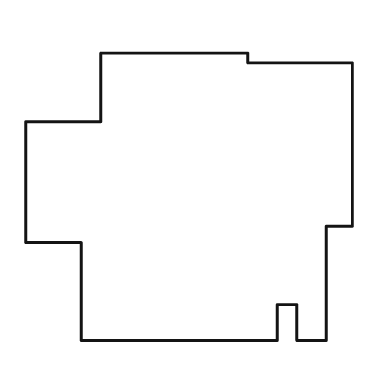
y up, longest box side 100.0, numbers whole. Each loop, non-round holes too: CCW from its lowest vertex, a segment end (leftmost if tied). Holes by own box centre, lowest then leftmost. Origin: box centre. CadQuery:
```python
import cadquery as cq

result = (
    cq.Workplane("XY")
    .moveTo(-33.0, -44.0)
    .lineTo(27.0, -44.0)
    .lineTo(27.0, -33.0)
    .lineTo(33.0, -33.0)
    .lineTo(33.0, -44.0)
    .lineTo(42.0, -44.0)
    .lineTo(42.0, -9.0)
    .lineTo(50.0, -9.0)
    .lineTo(50.0, 41.0)
    .lineTo(18.0, 41.0)
    .lineTo(18.0, 44.0)
    .lineTo(-27.0, 44.0)
    .lineTo(-27.0, 23.0)
    .lineTo(-50.0, 23.0)
    .lineTo(-50.0, -14.0)
    .lineTo(-33.0, -14.0)
    .close()
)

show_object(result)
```